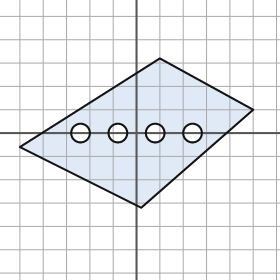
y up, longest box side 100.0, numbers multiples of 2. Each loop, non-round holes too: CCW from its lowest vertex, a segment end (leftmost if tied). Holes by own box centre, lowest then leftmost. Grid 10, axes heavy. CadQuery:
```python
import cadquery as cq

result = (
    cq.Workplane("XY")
    .moveTo(2.0, -32.0)
    .lineTo(50.0, 10.0)
    .lineTo(10.0, 32.0)
    .lineTo(-50.0, -6.0)
    .close()
    .moveTo(-24.0, 0.0)
    .circle(4.0)
    .moveTo(-8.0, 0.0)
    .circle(4.0)
    .moveTo(8.0, 0.0)
    .circle(4.0)
    .moveTo(24.0, 0.0)
    .circle(4.0)
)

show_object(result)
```